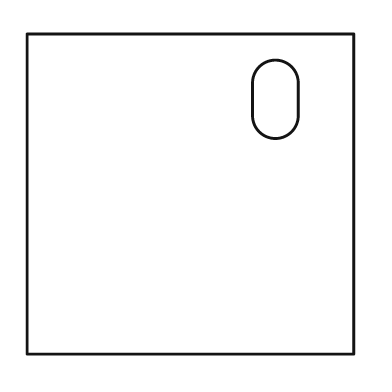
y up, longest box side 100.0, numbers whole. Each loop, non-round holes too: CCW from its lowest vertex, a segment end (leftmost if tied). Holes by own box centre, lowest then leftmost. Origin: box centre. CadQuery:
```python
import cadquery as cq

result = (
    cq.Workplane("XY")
    .moveTo(-50.0, -49.0)
    .lineTo(50.0, -49.0)
    .lineTo(50.0, 49.0)
    .lineTo(-50.0, 49.0)
    .close()
    .moveTo(19.0, 24.0)
    .threePointArc((26.0, 17.0), (33.0, 24.0))
    .lineTo(33.0, 34.0)
    .threePointArc((26.0, 41.0), (19.0, 34.0))
    .close()
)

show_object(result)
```